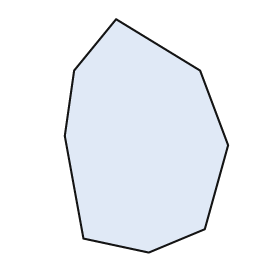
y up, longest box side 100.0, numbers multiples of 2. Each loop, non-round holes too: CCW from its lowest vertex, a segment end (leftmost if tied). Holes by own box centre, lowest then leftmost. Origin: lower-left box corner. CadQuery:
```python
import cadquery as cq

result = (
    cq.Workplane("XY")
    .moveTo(36.0, 0.0)
    .lineTo(60.0, 10.0)
    .lineTo(70.0, 46.0)
    .lineTo(58.0, 78.0)
    .lineTo(22.0, 100.0)
    .lineTo(4.0, 78.0)
    .lineTo(0.0, 50.0)
    .lineTo(8.0, 6.0)
    .close()
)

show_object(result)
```